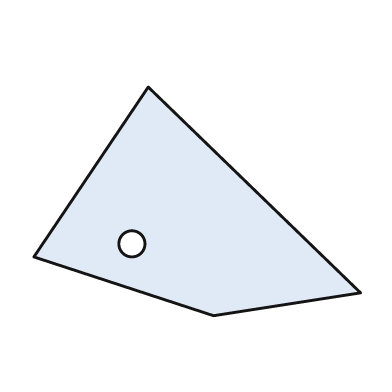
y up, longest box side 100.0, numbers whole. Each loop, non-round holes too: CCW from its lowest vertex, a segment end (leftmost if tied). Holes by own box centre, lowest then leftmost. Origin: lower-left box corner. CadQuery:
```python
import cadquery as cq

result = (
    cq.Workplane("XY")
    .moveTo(55.0, 0.0)
    .lineTo(100.0, 7.0)
    .lineTo(35.0, 70.0)
    .lineTo(0.0, 18.0)
    .close()
    .moveTo(30.0, 22.0)
    .circle(4.0)
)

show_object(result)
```